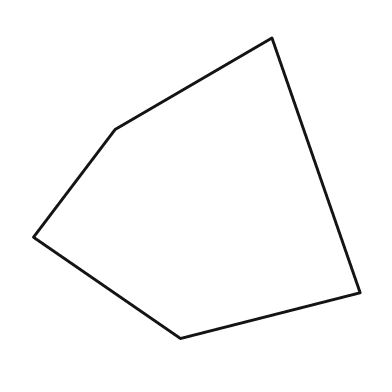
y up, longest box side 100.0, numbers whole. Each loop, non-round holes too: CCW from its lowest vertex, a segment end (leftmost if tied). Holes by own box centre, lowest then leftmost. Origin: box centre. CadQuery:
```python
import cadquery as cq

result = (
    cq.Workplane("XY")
    .moveTo(-5.0, -46.0)
    .lineTo(50.0, -32.0)
    .lineTo(23.0, 46.0)
    .lineTo(-25.0, 18.0)
    .lineTo(-50.0, -15.0)
    .close()
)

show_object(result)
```